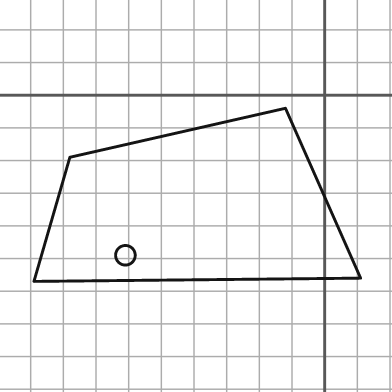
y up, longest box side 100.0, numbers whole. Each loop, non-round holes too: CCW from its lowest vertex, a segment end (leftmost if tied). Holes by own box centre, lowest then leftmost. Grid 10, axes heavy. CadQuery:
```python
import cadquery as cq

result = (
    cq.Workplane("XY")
    .moveTo(-89.0, -57.0)
    .lineTo(11.0, -56.0)
    .lineTo(-12.0, -4.0)
    .lineTo(-78.0, -19.0)
    .close()
    .moveTo(-61.0, -49.0)
    .circle(3.0)
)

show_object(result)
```